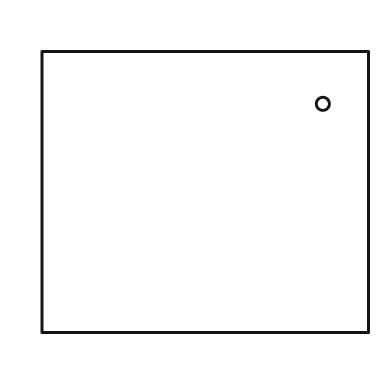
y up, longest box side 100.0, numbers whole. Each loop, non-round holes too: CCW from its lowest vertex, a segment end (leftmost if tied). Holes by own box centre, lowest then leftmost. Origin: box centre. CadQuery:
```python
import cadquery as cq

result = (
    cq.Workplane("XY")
    .moveTo(-50.0, -43.0)
    .lineTo(50.0, -43.0)
    .lineTo(50.0, 43.0)
    .lineTo(-50.0, 43.0)
    .close()
    .moveTo(36.0, 27.0)
    .circle(2.0)
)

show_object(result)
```